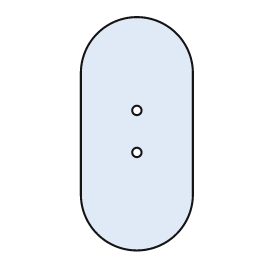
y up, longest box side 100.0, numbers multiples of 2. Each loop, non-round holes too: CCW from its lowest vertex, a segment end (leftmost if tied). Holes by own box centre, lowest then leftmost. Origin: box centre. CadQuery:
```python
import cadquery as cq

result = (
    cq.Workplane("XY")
    .moveTo(-24.0, -26.0)
    .threePointArc((0.0, -50.0), (24.0, -26.0))
    .lineTo(24.0, 26.0)
    .threePointArc((0.0, 50.0), (-24.0, 26.0))
    .close()
    .moveTo(0.0, -8.0)
    .circle(2.0)
    .moveTo(0.0, 10.0)
    .circle(2.0)
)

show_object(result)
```